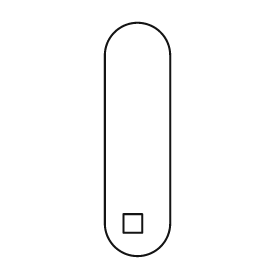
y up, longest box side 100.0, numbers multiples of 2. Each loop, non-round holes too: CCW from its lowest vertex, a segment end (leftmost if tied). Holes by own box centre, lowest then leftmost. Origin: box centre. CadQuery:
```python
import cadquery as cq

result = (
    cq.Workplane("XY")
    .moveTo(-14.0, -36.0)
    .threePointArc((0.0, -50.0), (14.0, -36.0))
    .lineTo(14.0, 36.0)
    .threePointArc((0.0, 50.0), (-14.0, 36.0))
    .close()
    .moveTo(-6.0, -40.0)
    .lineTo(2.0, -40.0)
    .lineTo(2.0, -32.0)
    .lineTo(-6.0, -32.0)
    .close()
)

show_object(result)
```